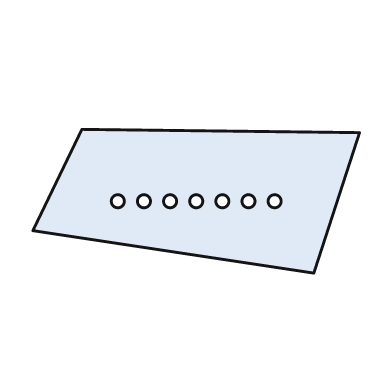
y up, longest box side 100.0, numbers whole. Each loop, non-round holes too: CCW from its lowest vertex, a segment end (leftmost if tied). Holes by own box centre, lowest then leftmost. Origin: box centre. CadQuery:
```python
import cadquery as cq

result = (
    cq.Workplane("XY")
    .moveTo(36.0, -22.0)
    .lineTo(50.0, 21.0)
    .lineTo(-35.0, 22.0)
    .lineTo(-50.0, -9.0)
    .close()
    .moveTo(-24.0, 0.0)
    .circle(2.0)
    .moveTo(-16.0, 0.0)
    .circle(2.0)
    .moveTo(-8.0, 0.0)
    .circle(2.0)
    .moveTo(0.0, 0.0)
    .circle(2.0)
    .moveTo(8.0, 0.0)
    .circle(2.0)
    .moveTo(16.0, 0.0)
    .circle(2.0)
    .moveTo(24.0, 0.0)
    .circle(2.0)
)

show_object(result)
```